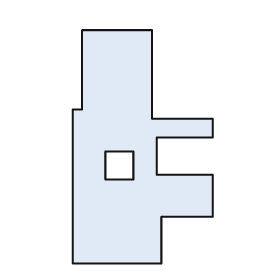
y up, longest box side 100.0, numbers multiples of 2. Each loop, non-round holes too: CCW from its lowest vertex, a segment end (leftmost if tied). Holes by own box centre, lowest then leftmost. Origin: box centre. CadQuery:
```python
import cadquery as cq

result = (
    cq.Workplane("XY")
    .moveTo(-30.0, -50.0)
    .lineTo(8.0, -50.0)
    .lineTo(8.0, -30.0)
    .lineTo(30.0, -30.0)
    .lineTo(30.0, -12.0)
    .lineTo(6.0, -12.0)
    .lineTo(6.0, 4.0)
    .lineTo(30.0, 4.0)
    .lineTo(30.0, 12.0)
    .lineTo(4.0, 12.0)
    .lineTo(4.0, 50.0)
    .lineTo(-26.0, 50.0)
    .lineTo(-26.0, 16.0)
    .lineTo(-30.0, 16.0)
    .close()
    .moveTo(-16.0, -14.0)
    .lineTo(-4.0, -14.0)
    .lineTo(-4.0, -2.0)
    .lineTo(-16.0, -2.0)
    .close()
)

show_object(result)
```